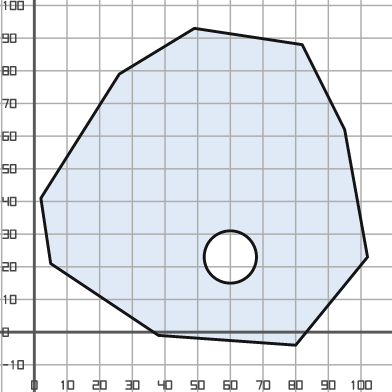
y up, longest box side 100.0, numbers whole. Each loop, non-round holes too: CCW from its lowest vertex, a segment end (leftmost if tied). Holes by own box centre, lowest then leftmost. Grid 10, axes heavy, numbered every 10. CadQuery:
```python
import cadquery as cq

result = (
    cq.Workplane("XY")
    .moveTo(80.0, -4.0)
    .lineTo(102.0, 23.0)
    .lineTo(95.0, 62.0)
    .lineTo(82.0, 88.0)
    .lineTo(49.0, 93.0)
    .lineTo(26.0, 79.0)
    .lineTo(2.0, 41.0)
    .lineTo(5.0, 21.0)
    .lineTo(38.0, -1.0)
    .close()
    .moveTo(60.0, 23.0)
    .circle(8.0)
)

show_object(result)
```